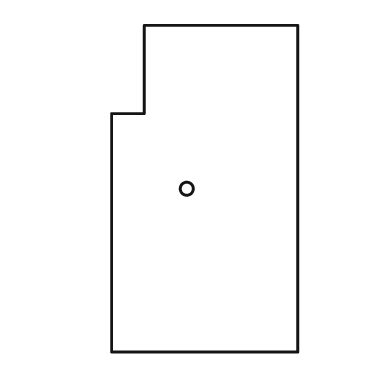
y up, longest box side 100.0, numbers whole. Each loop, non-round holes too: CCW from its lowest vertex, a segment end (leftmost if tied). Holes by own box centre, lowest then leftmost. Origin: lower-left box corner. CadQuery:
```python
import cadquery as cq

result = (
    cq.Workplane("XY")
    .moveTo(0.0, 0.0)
    .lineTo(57.0, 0.0)
    .lineTo(57.0, 100.0)
    .lineTo(10.0, 100.0)
    .lineTo(10.0, 73.0)
    .lineTo(0.0, 73.0)
    .close()
    .moveTo(23.0, 50.0)
    .circle(2.0)
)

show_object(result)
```